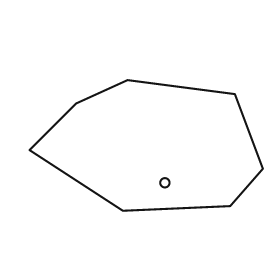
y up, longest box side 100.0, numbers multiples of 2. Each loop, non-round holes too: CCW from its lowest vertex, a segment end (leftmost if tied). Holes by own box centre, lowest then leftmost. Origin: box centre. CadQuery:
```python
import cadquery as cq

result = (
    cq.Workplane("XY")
    .moveTo(-10.0, -28.0)
    .lineTo(36.0, -26.0)
    .lineTo(50.0, -10.0)
    .lineTo(38.0, 22.0)
    .lineTo(-8.0, 28.0)
    .lineTo(-30.0, 18.0)
    .lineTo(-50.0, -2.0)
    .close()
    .moveTo(8.0, -16.0)
    .circle(2.0)
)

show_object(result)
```